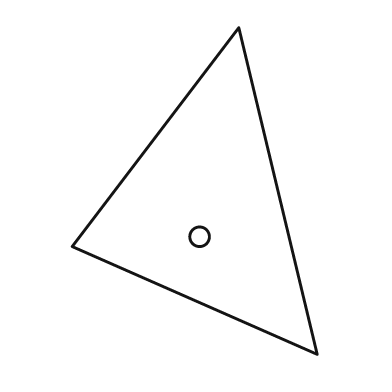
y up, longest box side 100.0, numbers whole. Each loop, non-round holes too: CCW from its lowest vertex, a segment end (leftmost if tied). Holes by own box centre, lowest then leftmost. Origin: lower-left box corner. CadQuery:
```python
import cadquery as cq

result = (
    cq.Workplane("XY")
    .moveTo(75.0, 0.0)
    .lineTo(51.0, 100.0)
    .lineTo(0.0, 33.0)
    .close()
    .moveTo(39.0, 36.0)
    .circle(3.0)
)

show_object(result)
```